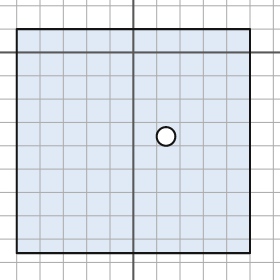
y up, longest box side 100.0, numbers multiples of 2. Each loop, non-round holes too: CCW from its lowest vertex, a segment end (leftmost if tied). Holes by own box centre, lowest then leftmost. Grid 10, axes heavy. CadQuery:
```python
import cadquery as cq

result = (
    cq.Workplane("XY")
    .moveTo(-50.0, -86.0)
    .lineTo(50.0, -86.0)
    .lineTo(50.0, 10.0)
    .lineTo(-50.0, 10.0)
    .close()
    .moveTo(14.0, -36.0)
    .circle(4.0)
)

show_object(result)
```